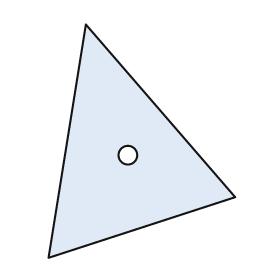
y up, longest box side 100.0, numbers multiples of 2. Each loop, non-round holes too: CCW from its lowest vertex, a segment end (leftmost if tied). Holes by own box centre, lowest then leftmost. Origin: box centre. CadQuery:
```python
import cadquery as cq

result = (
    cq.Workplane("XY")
    .moveTo(-40.0, -50.0)
    .lineTo(40.0, -24.0)
    .lineTo(-24.0, 50.0)
    .close()
    .moveTo(-6.0, -6.0)
    .circle(4.0)
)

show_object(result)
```